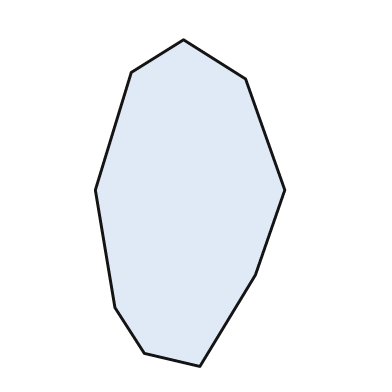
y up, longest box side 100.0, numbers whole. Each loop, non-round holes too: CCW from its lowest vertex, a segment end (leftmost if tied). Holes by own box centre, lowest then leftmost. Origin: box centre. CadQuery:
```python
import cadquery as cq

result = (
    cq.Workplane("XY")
    .moveTo(3.0, -50.0)
    .lineTo(20.0, -22.0)
    .lineTo(29.0, 4.0)
    .lineTo(17.0, 38.0)
    .lineTo(-2.0, 50.0)
    .lineTo(-18.0, 40.0)
    .lineTo(-29.0, 4.0)
    .lineTo(-23.0, -32.0)
    .lineTo(-14.0, -46.0)
    .close()
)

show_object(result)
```